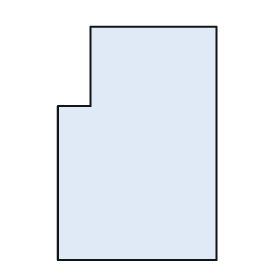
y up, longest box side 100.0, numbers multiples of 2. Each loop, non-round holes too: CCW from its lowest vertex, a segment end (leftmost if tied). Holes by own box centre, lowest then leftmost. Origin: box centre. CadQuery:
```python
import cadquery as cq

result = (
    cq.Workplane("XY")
    .moveTo(-34.0, -50.0)
    .lineTo(34.0, -50.0)
    .lineTo(34.0, 50.0)
    .lineTo(-20.0, 50.0)
    .lineTo(-20.0, 16.0)
    .lineTo(-34.0, 16.0)
    .close()
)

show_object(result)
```